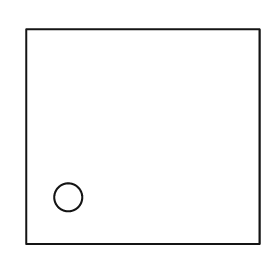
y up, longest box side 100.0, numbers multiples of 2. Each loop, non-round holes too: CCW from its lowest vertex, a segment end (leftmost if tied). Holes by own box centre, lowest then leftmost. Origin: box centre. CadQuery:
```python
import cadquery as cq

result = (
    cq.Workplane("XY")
    .moveTo(-50.0, -46.0)
    .lineTo(50.0, -46.0)
    .lineTo(50.0, 46.0)
    .lineTo(-50.0, 46.0)
    .close()
    .moveTo(-32.0, -26.0)
    .circle(6.0)
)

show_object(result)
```